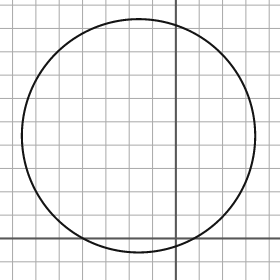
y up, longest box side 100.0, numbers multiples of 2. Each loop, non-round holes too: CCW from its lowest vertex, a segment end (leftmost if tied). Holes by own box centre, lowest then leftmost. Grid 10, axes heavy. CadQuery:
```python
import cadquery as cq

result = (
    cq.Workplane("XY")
    .moveTo(-16.0, 44.0)
    .circle(50.0)
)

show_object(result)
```